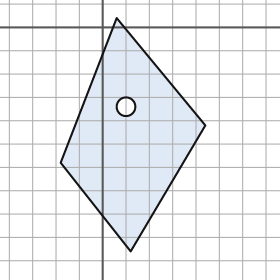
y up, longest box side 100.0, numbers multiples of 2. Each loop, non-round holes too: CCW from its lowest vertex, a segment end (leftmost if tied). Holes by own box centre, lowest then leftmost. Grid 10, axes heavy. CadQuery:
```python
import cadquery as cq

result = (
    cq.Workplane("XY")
    .moveTo(12.0, -96.0)
    .lineTo(44.0, -42.0)
    .lineTo(6.0, 4.0)
    .lineTo(-18.0, -58.0)
    .close()
    .moveTo(10.0, -34.0)
    .circle(4.0)
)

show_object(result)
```